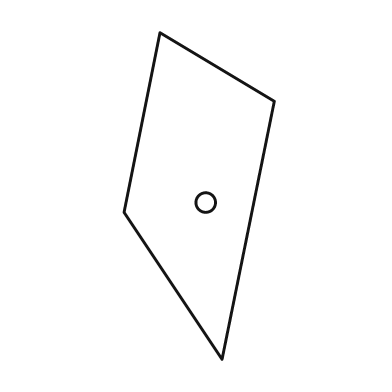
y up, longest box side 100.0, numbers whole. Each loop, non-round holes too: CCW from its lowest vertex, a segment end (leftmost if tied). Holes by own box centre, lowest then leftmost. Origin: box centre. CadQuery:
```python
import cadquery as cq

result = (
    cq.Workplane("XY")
    .moveTo(7.0, -50.0)
    .lineTo(23.0, 29.0)
    .lineTo(-12.0, 50.0)
    .lineTo(-23.0, -5.0)
    .close()
    .moveTo(2.0, -2.0)
    .circle(3.0)
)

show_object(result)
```